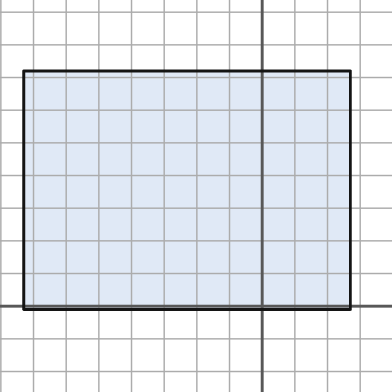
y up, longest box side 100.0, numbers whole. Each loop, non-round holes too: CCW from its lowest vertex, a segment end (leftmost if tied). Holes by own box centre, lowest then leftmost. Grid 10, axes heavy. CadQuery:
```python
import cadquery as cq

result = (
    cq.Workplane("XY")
    .moveTo(-73.0, -1.0)
    .lineTo(27.0, -1.0)
    .lineTo(27.0, 72.0)
    .lineTo(-73.0, 72.0)
    .close()
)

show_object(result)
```